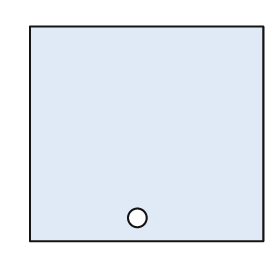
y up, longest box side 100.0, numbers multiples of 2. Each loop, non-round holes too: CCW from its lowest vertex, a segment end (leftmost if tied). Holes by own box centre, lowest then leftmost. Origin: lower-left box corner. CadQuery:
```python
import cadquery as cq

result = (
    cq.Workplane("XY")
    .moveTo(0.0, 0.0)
    .lineTo(100.0, 0.0)
    .lineTo(100.0, 92.0)
    .lineTo(0.0, 92.0)
    .close()
    .moveTo(46.0, 10.0)
    .circle(4.0)
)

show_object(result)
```